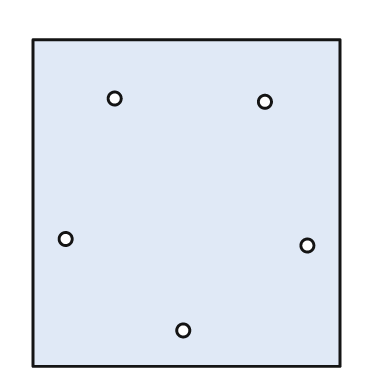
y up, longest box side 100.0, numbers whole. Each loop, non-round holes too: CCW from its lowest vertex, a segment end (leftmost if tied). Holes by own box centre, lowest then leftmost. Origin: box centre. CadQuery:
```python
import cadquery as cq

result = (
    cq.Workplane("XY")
    .moveTo(-47.0, -50.0)
    .lineTo(47.0, -50.0)
    .lineTo(47.0, 50.0)
    .lineTo(-47.0, 50.0)
    .close()
    .moveTo(-1.0, -39.0)
    .circle(2.0)
    .moveTo(37.0, -13.0)
    .circle(2.0)
    .moveTo(-37.0, -11.0)
    .circle(2.0)
    .moveTo(24.0, 31.0)
    .circle(2.0)
    .moveTo(-22.0, 32.0)
    .circle(2.0)
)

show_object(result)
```